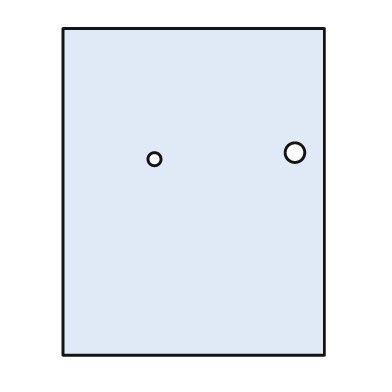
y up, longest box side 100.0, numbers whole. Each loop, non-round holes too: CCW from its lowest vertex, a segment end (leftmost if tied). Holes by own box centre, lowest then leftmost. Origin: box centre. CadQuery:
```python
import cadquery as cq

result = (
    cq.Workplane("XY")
    .moveTo(-40.0, -50.0)
    .lineTo(40.0, -50.0)
    .lineTo(40.0, 50.0)
    .lineTo(-40.0, 50.0)
    .close()
    .moveTo(-12.0, 10.0)
    .circle(2.0)
    .moveTo(31.0, 12.0)
    .circle(3.0)
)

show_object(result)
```